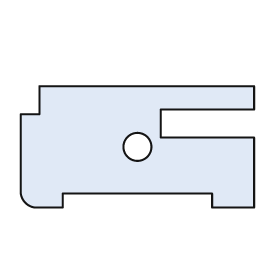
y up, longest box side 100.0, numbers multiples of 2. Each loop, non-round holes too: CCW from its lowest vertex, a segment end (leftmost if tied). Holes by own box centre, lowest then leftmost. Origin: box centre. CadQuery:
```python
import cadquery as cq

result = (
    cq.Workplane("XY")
    .moveTo(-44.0, -26.0)
    .lineTo(-32.0, -26.0)
    .lineTo(-32.0, -20.0)
    .lineTo(32.0, -20.0)
    .lineTo(32.0, -26.0)
    .lineTo(50.0, -26.0)
    .lineTo(50.0, 4.0)
    .lineTo(10.0, 4.0)
    .lineTo(10.0, 16.0)
    .lineTo(50.0, 16.0)
    .lineTo(50.0, 26.0)
    .lineTo(-42.0, 26.0)
    .lineTo(-42.0, 14.0)
    .lineTo(-50.0, 14.0)
    .lineTo(-50.0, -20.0)
    .threePointArc((-48.0, -24.0), (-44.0, -26.0))
    .close()
    .moveTo(0.0, 0.0)
    .circle(6.0)
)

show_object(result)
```